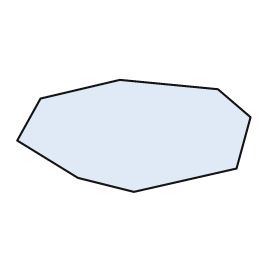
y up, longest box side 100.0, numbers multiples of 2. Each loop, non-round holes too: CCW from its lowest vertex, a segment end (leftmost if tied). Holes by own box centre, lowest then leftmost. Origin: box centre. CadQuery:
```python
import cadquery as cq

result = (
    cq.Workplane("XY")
    .moveTo(0.0, -24.0)
    .lineTo(44.0, -14.0)
    .lineTo(50.0, 8.0)
    .lineTo(36.0, 20.0)
    .lineTo(-6.0, 24.0)
    .lineTo(-40.0, 16.0)
    .lineTo(-50.0, -2.0)
    .lineTo(-24.0, -18.0)
    .close()
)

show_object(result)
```